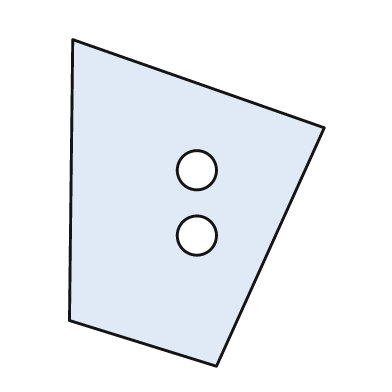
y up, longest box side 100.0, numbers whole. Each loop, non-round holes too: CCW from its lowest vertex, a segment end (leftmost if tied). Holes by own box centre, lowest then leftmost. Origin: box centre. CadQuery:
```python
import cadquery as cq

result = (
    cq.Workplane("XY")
    .moveTo(6.0, -50.0)
    .lineTo(39.0, 23.0)
    .lineTo(-38.0, 50.0)
    .lineTo(-39.0, -36.0)
    .close()
    .moveTo(0.0, -10.0)
    .circle(6.0)
    .moveTo(0.0, 10.0)
    .circle(6.0)
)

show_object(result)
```